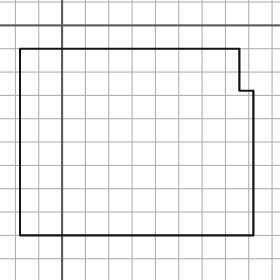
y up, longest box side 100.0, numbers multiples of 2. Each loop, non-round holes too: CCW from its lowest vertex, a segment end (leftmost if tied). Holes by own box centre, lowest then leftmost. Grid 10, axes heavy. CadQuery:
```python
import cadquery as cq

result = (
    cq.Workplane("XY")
    .moveTo(-18.0, -90.0)
    .lineTo(82.0, -90.0)
    .lineTo(82.0, -28.0)
    .lineTo(76.0, -28.0)
    .lineTo(76.0, -10.0)
    .lineTo(-18.0, -10.0)
    .close()
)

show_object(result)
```